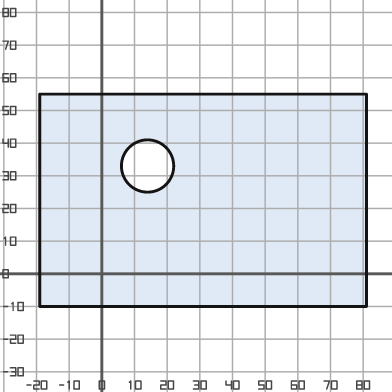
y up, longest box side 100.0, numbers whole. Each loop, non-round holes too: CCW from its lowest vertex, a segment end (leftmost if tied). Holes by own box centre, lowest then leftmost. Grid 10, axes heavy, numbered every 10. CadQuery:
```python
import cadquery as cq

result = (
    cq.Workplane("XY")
    .moveTo(-19.0, -10.0)
    .lineTo(81.0, -10.0)
    .lineTo(81.0, 55.0)
    .lineTo(-19.0, 55.0)
    .close()
    .moveTo(14.0, 33.0)
    .circle(8.0)
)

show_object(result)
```